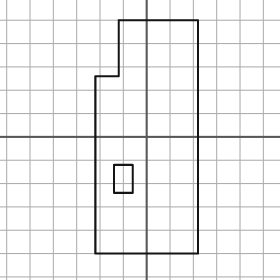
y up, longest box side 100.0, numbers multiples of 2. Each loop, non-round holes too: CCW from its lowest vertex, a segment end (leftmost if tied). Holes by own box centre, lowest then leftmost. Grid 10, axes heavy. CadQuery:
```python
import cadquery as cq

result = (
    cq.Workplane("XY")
    .moveTo(-22.0, -50.0)
    .lineTo(22.0, -50.0)
    .lineTo(22.0, 50.0)
    .lineTo(-12.0, 50.0)
    .lineTo(-12.0, 26.0)
    .lineTo(-22.0, 26.0)
    .close()
    .moveTo(-14.0, -24.0)
    .lineTo(-6.0, -24.0)
    .lineTo(-6.0, -12.0)
    .lineTo(-14.0, -12.0)
    .close()
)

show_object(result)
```